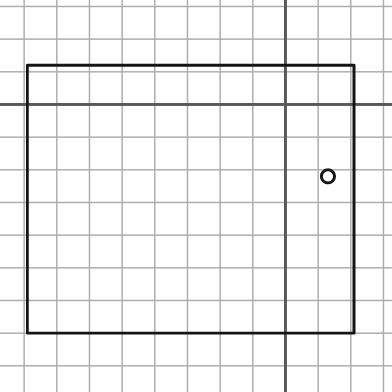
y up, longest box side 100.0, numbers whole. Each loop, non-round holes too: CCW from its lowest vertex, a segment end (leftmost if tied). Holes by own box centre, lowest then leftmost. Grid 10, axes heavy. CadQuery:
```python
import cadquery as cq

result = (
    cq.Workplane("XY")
    .moveTo(-79.0, -70.0)
    .lineTo(21.0, -70.0)
    .lineTo(21.0, 12.0)
    .lineTo(-79.0, 12.0)
    .close()
    .moveTo(13.0, -22.0)
    .circle(2.0)
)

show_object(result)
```